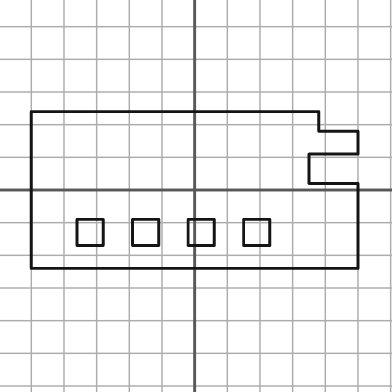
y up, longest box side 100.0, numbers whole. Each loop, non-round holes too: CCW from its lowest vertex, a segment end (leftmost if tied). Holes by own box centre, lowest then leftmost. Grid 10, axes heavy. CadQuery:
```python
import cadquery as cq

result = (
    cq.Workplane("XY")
    .moveTo(-50.0, -24.0)
    .lineTo(50.0, -24.0)
    .lineTo(50.0, 2.0)
    .lineTo(35.0, 2.0)
    .lineTo(35.0, 11.0)
    .lineTo(50.0, 11.0)
    .lineTo(50.0, 18.0)
    .lineTo(38.0, 18.0)
    .lineTo(38.0, 24.0)
    .lineTo(-50.0, 24.0)
    .close()
    .moveTo(-36.0, -17.0)
    .lineTo(-28.0, -17.0)
    .lineTo(-28.0, -9.0)
    .lineTo(-36.0, -9.0)
    .close()
    .moveTo(-19.0, -17.0)
    .lineTo(-11.0, -17.0)
    .lineTo(-11.0, -9.0)
    .lineTo(-19.0, -9.0)
    .close()
    .moveTo(-2.0, -17.0)
    .lineTo(6.0, -17.0)
    .lineTo(6.0, -9.0)
    .lineTo(-2.0, -9.0)
    .close()
    .moveTo(15.0, -17.0)
    .lineTo(23.0, -17.0)
    .lineTo(23.0, -9.0)
    .lineTo(15.0, -9.0)
    .close()
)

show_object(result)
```